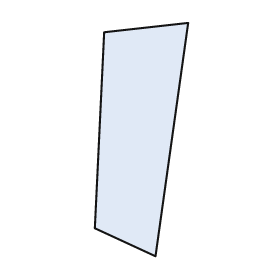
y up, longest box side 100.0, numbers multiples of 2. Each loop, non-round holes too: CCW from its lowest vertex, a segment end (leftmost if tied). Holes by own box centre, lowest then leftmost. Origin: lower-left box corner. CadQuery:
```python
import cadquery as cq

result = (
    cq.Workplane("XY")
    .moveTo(26.0, 0.0)
    .lineTo(40.0, 100.0)
    .lineTo(4.0, 96.0)
    .lineTo(0.0, 12.0)
    .close()
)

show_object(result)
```